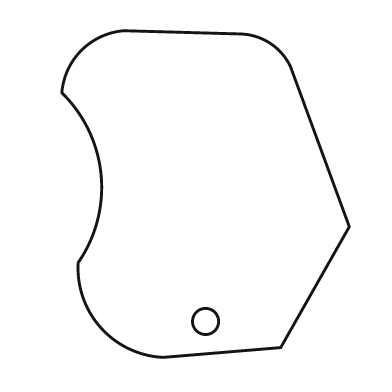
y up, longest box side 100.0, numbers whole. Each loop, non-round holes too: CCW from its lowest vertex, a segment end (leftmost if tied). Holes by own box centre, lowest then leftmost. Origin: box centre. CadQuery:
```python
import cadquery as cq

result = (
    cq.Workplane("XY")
    .moveTo(-13.0, -50.0)
    .lineTo(23.0, -47.0)
    .lineTo(44.0, -10.0)
    .lineTo(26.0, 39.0)
    .threePointArc((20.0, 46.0), (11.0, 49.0))
    .lineTo(-25.0, 50.0)
    .threePointArc((-38.0, 44.0), (-44.0, 31.0))
    .threePointArc((-32.0, 6.0), (-39.0, -21.0))
    .threePointArc((-32.0, -41.0), (-13.0, -50.0))
    .close()
    .moveTo(0.0, -39.0)
    .circle(4.0)
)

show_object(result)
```